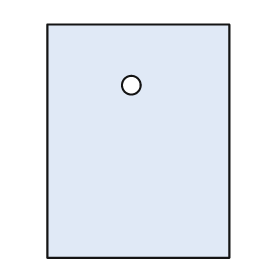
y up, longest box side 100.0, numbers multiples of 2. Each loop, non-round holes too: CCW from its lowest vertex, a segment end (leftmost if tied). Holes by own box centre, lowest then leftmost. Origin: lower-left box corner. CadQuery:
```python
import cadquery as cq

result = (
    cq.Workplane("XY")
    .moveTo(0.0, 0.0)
    .lineTo(78.0, 0.0)
    .lineTo(78.0, 100.0)
    .lineTo(0.0, 100.0)
    .close()
    .moveTo(36.0, 74.0)
    .circle(4.0)
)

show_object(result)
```